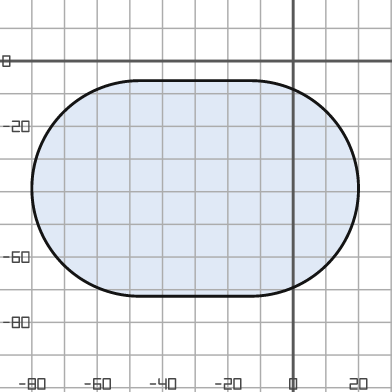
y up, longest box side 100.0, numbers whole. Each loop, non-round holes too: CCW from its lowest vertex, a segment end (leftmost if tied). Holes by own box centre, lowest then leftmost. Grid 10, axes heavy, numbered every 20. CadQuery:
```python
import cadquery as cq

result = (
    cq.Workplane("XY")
    .moveTo(-47.0, -72.0)
    .lineTo(-13.0, -72.0)
    .threePointArc((20.0, -39.0), (-13.0, -6.0))
    .lineTo(-47.0, -6.0)
    .threePointArc((-80.0, -39.0), (-47.0, -72.0))
    .close()
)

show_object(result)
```